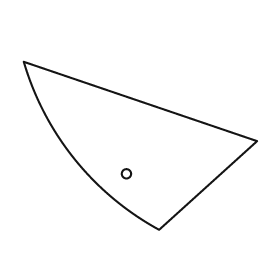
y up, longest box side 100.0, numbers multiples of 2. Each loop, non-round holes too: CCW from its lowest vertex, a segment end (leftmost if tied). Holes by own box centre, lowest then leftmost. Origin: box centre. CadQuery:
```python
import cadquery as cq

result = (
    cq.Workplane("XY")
    .moveTo(8.0, -36.0)
    .lineTo(50.0, 2.0)
    .lineTo(-50.0, 36.0)
    .threePointArc((-28.0, -6.0), (8.0, -36.0))
    .close()
    .moveTo(-6.0, -12.0)
    .circle(2.0)
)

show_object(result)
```